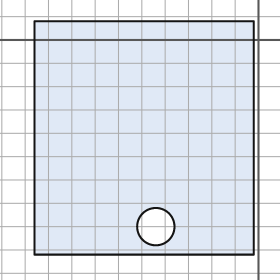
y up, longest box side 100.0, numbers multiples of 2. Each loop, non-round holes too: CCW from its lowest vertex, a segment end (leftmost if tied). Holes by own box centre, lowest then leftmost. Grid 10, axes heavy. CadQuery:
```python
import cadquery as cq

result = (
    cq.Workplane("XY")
    .moveTo(-96.0, -92.0)
    .lineTo(-2.0, -92.0)
    .lineTo(-2.0, 8.0)
    .lineTo(-96.0, 8.0)
    .close()
    .moveTo(-44.0, -80.0)
    .circle(8.0)
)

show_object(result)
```